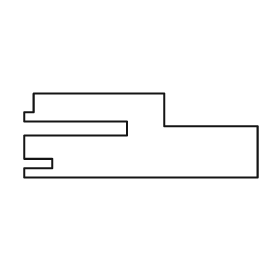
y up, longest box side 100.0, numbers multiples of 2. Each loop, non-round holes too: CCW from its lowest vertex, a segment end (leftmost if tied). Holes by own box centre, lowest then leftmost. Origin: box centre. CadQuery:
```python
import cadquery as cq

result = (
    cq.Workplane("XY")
    .moveTo(-50.0, -18.0)
    .lineTo(50.0, -18.0)
    .lineTo(50.0, 4.0)
    .lineTo(10.0, 4.0)
    .lineTo(10.0, 18.0)
    .lineTo(-46.0, 18.0)
    .lineTo(-46.0, 10.0)
    .lineTo(-50.0, 10.0)
    .lineTo(-50.0, 6.0)
    .lineTo(-6.0, 6.0)
    .lineTo(-6.0, 0.0)
    .lineTo(-50.0, 0.0)
    .lineTo(-50.0, -10.0)
    .lineTo(-38.0, -10.0)
    .lineTo(-38.0, -14.0)
    .lineTo(-50.0, -14.0)
    .close()
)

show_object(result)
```